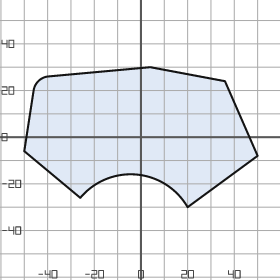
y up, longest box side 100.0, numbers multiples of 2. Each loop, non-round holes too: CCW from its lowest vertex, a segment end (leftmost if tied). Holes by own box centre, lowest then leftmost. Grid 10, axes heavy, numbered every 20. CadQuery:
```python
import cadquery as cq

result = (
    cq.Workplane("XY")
    .moveTo(20.0, -30.0)
    .lineTo(50.0, -8.0)
    .lineTo(36.0, 24.0)
    .lineTo(4.0, 30.0)
    .lineTo(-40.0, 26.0)
    .threePointArc((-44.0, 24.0), (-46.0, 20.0))
    .lineTo(-50.0, -6.0)
    .lineTo(-26.0, -26.0)
    .threePointArc((-2.0, -16.0), (20.0, -30.0))
    .close()
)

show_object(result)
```